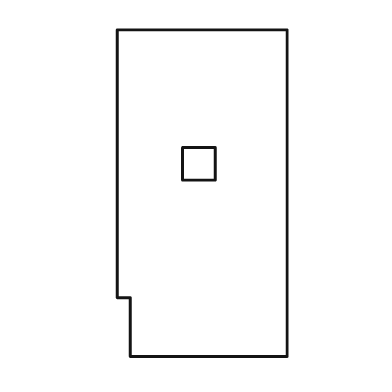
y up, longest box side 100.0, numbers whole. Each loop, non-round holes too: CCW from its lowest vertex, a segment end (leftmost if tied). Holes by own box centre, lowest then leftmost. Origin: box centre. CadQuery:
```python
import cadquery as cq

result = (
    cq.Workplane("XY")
    .moveTo(-22.0, -50.0)
    .lineTo(26.0, -50.0)
    .lineTo(26.0, 50.0)
    .lineTo(-26.0, 50.0)
    .lineTo(-26.0, -32.0)
    .lineTo(-22.0, -32.0)
    .close()
    .moveTo(-6.0, 4.0)
    .lineTo(4.0, 4.0)
    .lineTo(4.0, 14.0)
    .lineTo(-6.0, 14.0)
    .close()
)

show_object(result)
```